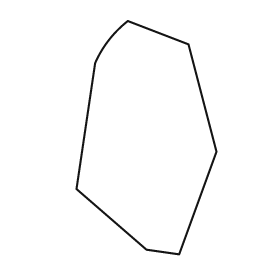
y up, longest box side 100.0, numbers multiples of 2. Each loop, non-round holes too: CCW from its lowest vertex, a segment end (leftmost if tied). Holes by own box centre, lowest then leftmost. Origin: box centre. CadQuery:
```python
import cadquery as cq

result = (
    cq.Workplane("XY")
    .moveTo(14.0, -50.0)
    .lineTo(30.0, -6.0)
    .lineTo(18.0, 40.0)
    .lineTo(-8.0, 50.0)
    .threePointArc((-16.0, 42.0), (-22.0, 32.0))
    .lineTo(-30.0, -22.0)
    .lineTo(0.0, -48.0)
    .close()
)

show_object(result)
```